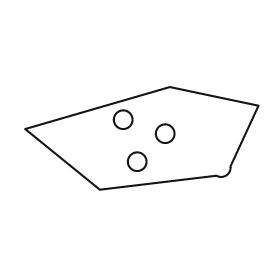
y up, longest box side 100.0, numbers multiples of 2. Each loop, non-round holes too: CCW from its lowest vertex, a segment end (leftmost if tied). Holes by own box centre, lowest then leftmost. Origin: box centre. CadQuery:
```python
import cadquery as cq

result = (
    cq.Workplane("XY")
    .moveTo(-18.0, -22.0)
    .lineTo(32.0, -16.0)
    .threePointArc((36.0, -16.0), (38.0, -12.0))
    .lineTo(50.0, 14.0)
    .lineTo(12.0, 22.0)
    .lineTo(-50.0, 4.0)
    .close()
    .moveTo(-2.0, -10.0)
    .circle(4.0)
    .moveTo(10.0, 2.0)
    .circle(4.0)
    .moveTo(-8.0, 8.0)
    .circle(4.0)
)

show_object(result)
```